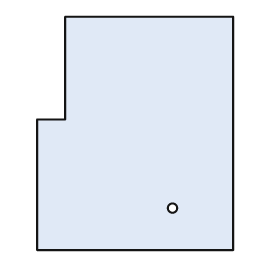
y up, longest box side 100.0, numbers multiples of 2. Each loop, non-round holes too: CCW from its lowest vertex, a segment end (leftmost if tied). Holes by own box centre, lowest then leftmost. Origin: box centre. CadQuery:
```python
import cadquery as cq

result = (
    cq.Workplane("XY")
    .moveTo(-42.0, -50.0)
    .lineTo(42.0, -50.0)
    .lineTo(42.0, 50.0)
    .lineTo(-30.0, 50.0)
    .lineTo(-30.0, 6.0)
    .lineTo(-42.0, 6.0)
    .close()
    .moveTo(16.0, -32.0)
    .circle(2.0)
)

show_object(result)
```